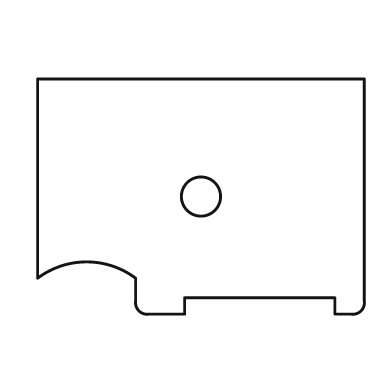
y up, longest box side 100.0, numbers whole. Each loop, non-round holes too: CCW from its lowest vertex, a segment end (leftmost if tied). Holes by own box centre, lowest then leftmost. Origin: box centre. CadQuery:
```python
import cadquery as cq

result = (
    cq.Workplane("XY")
    .moveTo(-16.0, -36.0)
    .lineTo(-5.0, -36.0)
    .lineTo(-5.0, -31.0)
    .lineTo(41.0, -31.0)
    .lineTo(41.0, -36.0)
    .lineTo(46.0, -36.0)
    .threePointArc((49.0, -35.0), (50.0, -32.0))
    .lineTo(50.0, 36.0)
    .lineTo(-50.0, 36.0)
    .lineTo(-50.0, -25.0)
    .threePointArc((-35.0, -20.0), (-20.0, -25.0))
    .lineTo(-20.0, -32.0)
    .threePointArc((-19.0, -35.0), (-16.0, -36.0))
    .close()
    .moveTo(0.0, 0.0)
    .circle(6.0)
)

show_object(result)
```